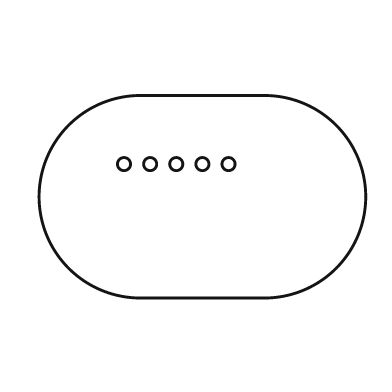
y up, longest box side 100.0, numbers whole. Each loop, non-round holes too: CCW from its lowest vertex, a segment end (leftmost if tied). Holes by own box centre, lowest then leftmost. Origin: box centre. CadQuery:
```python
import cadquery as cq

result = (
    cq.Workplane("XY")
    .moveTo(-19.0, -31.0)
    .lineTo(19.0, -31.0)
    .threePointArc((50.0, 0.0), (19.0, 31.0))
    .lineTo(-19.0, 31.0)
    .threePointArc((-50.0, 0.0), (-19.0, -31.0))
    .close()
    .moveTo(-24.0, 10.0)
    .circle(2.0)
    .moveTo(-16.0, 10.0)
    .circle(2.0)
    .moveTo(-8.0, 10.0)
    .circle(2.0)
    .moveTo(0.0, 10.0)
    .circle(2.0)
    .moveTo(8.0, 10.0)
    .circle(2.0)
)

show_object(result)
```